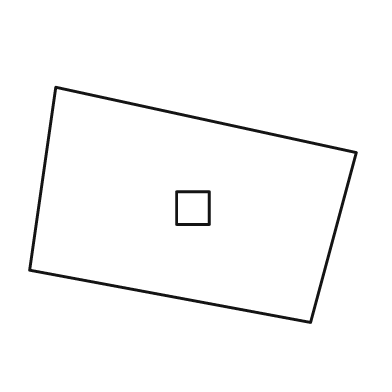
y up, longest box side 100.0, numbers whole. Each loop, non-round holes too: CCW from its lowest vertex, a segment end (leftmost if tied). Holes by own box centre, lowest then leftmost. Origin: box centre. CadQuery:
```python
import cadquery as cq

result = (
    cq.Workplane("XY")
    .moveTo(36.0, -36.0)
    .lineTo(50.0, 16.0)
    .lineTo(-42.0, 36.0)
    .lineTo(-50.0, -20.0)
    .close()
    .moveTo(-5.0, -6.0)
    .lineTo(5.0, -6.0)
    .lineTo(5.0, 4.0)
    .lineTo(-5.0, 4.0)
    .close()
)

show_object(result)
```